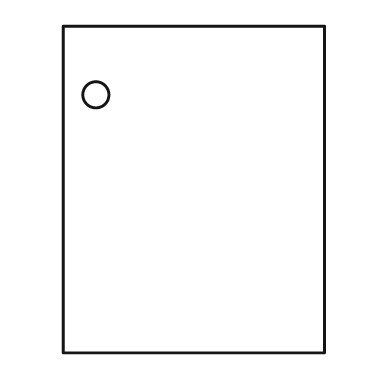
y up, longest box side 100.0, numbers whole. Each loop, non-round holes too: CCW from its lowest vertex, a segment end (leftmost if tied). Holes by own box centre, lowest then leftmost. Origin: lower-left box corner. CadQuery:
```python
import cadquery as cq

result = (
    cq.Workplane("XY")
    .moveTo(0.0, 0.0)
    .lineTo(80.0, 0.0)
    .lineTo(80.0, 100.0)
    .lineTo(0.0, 100.0)
    .close()
    .moveTo(10.0, 79.0)
    .circle(4.0)
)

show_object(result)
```